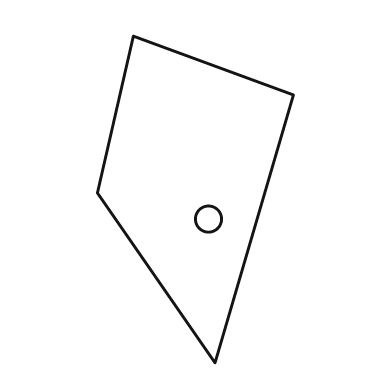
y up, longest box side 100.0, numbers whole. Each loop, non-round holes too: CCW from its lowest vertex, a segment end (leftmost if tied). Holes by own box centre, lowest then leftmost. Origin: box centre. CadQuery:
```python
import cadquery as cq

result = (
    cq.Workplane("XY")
    .moveTo(6.0, -50.0)
    .lineTo(30.0, 32.0)
    .lineTo(-19.0, 50.0)
    .lineTo(-30.0, 2.0)
    .close()
    .moveTo(4.0, -6.0)
    .circle(4.0)
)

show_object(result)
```